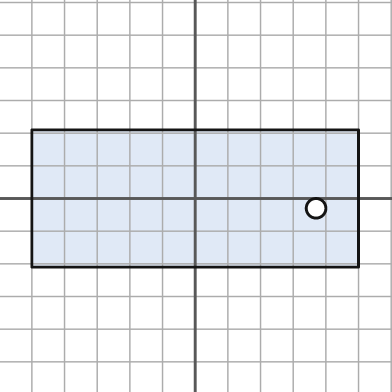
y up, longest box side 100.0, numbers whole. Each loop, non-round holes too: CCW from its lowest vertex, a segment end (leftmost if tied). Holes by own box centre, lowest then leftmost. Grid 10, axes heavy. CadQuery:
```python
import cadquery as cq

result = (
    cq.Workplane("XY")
    .moveTo(-50.0, -21.0)
    .lineTo(50.0, -21.0)
    .lineTo(50.0, 21.0)
    .lineTo(-50.0, 21.0)
    .close()
    .moveTo(37.0, -3.0)
    .circle(3.0)
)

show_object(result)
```